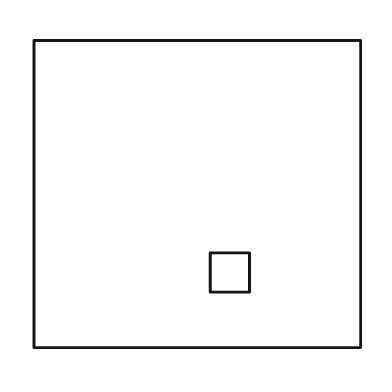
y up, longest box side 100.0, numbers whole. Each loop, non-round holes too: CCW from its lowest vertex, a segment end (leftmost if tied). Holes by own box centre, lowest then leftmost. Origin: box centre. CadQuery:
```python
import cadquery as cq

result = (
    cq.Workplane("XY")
    .moveTo(-50.0, -47.0)
    .lineTo(50.0, -47.0)
    .lineTo(50.0, 47.0)
    .lineTo(-50.0, 47.0)
    .close()
    .moveTo(4.0, -30.0)
    .lineTo(16.0, -30.0)
    .lineTo(16.0, -18.0)
    .lineTo(4.0, -18.0)
    .close()
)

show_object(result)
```